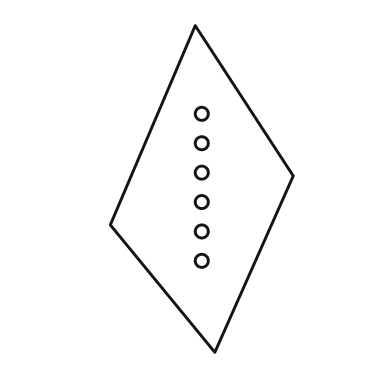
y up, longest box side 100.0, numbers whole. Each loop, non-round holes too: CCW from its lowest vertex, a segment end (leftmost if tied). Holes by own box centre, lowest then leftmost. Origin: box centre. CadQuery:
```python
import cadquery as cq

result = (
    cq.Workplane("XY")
    .moveTo(4.0, -50.0)
    .lineTo(28.0, 4.0)
    .lineTo(-2.0, 50.0)
    .lineTo(-28.0, -11.0)
    .close()
    .moveTo(0.0, -22.0)
    .circle(2.0)
    .moveTo(0.0, -13.0)
    .circle(2.0)
    .moveTo(0.0, -4.0)
    .circle(2.0)
    .moveTo(0.0, 5.0)
    .circle(2.0)
    .moveTo(0.0, 14.0)
    .circle(2.0)
    .moveTo(0.0, 23.0)
    .circle(2.0)
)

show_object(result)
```